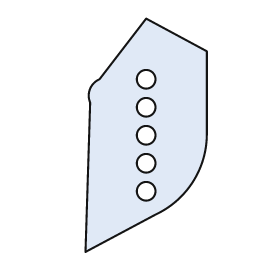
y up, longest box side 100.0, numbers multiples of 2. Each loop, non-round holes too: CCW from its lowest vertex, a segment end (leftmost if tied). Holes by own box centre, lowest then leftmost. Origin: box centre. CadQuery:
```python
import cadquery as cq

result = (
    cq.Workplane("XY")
    .moveTo(-26.0, -50.0)
    .lineTo(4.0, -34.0)
    .threePointArc((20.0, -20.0), (26.0, 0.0))
    .lineTo(26.0, 36.0)
    .lineTo(0.0, 50.0)
    .lineTo(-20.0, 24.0)
    .threePointArc((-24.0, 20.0), (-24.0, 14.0))
    .close()
    .moveTo(0.0, -24.0)
    .circle(4.0)
    .moveTo(0.0, -12.0)
    .circle(4.0)
    .moveTo(0.0, 0.0)
    .circle(4.0)
    .moveTo(0.0, 12.0)
    .circle(4.0)
    .moveTo(0.0, 24.0)
    .circle(4.0)
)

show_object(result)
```